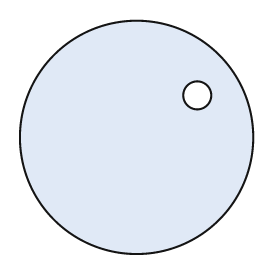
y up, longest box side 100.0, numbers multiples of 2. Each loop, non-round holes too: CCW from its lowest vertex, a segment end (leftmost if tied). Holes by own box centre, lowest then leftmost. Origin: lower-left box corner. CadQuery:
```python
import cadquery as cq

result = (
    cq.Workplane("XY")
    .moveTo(50.0, 50.0)
    .circle(50.0)
    .moveTo(76.0, 68.0)
    .circle(6.0)
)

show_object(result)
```